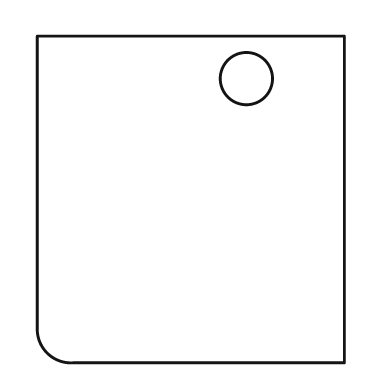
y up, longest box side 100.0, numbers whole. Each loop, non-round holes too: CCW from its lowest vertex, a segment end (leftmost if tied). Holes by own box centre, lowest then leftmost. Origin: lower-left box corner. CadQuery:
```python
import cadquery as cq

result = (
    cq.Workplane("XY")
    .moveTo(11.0, 0.0)
    .lineTo(94.0, 0.0)
    .lineTo(94.0, 100.0)
    .lineTo(0.0, 100.0)
    .lineTo(0.0, 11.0)
    .threePointArc((3.0, 3.0), (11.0, 0.0))
    .close()
    .moveTo(64.0, 87.0)
    .circle(8.0)
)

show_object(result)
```